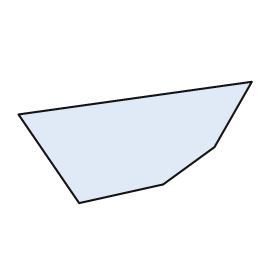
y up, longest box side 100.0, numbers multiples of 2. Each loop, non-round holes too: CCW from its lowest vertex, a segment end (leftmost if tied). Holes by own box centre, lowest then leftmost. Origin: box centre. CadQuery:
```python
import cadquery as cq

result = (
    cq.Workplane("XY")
    .moveTo(-24.0, -26.0)
    .lineTo(12.0, -18.0)
    .lineTo(34.0, -2.0)
    .lineTo(50.0, 26.0)
    .lineTo(-50.0, 12.0)
    .close()
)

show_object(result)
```